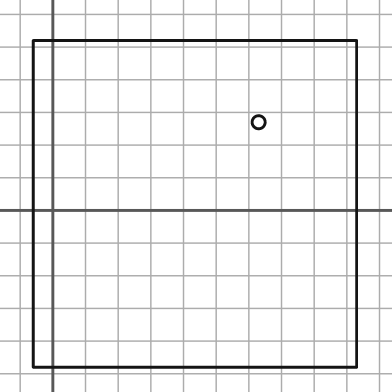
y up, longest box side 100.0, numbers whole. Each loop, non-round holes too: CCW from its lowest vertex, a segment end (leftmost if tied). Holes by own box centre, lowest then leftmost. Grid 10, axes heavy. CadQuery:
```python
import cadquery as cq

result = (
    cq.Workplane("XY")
    .moveTo(-6.0, -48.0)
    .lineTo(93.0, -48.0)
    .lineTo(93.0, 52.0)
    .lineTo(-6.0, 52.0)
    .close()
    .moveTo(63.0, 27.0)
    .circle(2.0)
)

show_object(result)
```